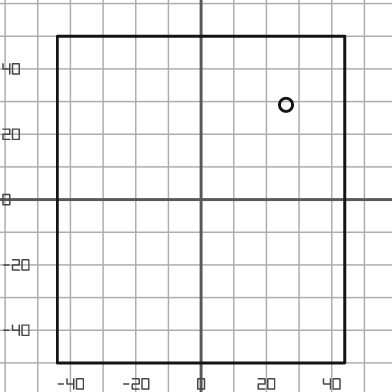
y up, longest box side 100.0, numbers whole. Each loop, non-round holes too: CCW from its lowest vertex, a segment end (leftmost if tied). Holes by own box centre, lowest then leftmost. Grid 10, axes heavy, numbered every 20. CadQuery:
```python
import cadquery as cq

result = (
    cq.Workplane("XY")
    .moveTo(-44.0, -50.0)
    .lineTo(44.0, -50.0)
    .lineTo(44.0, 50.0)
    .lineTo(-44.0, 50.0)
    .close()
    .moveTo(26.0, 29.0)
    .circle(2.0)
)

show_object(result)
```